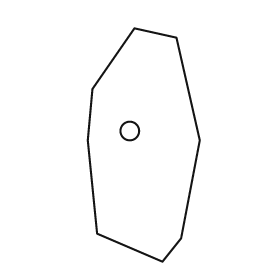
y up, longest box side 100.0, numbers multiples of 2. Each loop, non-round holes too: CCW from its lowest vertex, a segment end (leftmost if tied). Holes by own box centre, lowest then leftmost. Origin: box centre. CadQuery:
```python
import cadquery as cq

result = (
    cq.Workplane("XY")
    .moveTo(8.0, -50.0)
    .lineTo(16.0, -40.0)
    .lineTo(24.0, 2.0)
    .lineTo(14.0, 46.0)
    .lineTo(-4.0, 50.0)
    .lineTo(-22.0, 24.0)
    .lineTo(-24.0, 2.0)
    .lineTo(-20.0, -38.0)
    .close()
    .moveTo(-6.0, 6.0)
    .circle(4.0)
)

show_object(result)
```